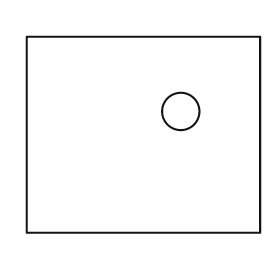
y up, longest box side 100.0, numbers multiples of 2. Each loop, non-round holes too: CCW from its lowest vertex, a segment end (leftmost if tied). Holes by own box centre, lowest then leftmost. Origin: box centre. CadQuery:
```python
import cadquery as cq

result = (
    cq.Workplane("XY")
    .moveTo(-50.0, -42.0)
    .lineTo(50.0, -42.0)
    .lineTo(50.0, 42.0)
    .lineTo(-50.0, 42.0)
    .close()
    .moveTo(16.0, 10.0)
    .circle(8.0)
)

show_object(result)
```